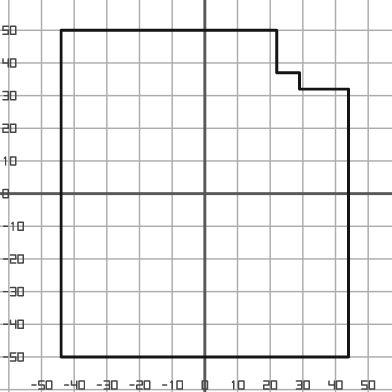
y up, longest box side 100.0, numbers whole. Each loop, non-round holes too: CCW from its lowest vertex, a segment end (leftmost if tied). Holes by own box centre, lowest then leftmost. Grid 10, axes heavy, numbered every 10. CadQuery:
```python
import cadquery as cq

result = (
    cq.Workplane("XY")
    .moveTo(-44.0, -50.0)
    .lineTo(44.0, -50.0)
    .lineTo(44.0, 32.0)
    .lineTo(29.0, 32.0)
    .lineTo(29.0, 37.0)
    .lineTo(22.0, 37.0)
    .lineTo(22.0, 50.0)
    .lineTo(-44.0, 50.0)
    .close()
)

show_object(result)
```